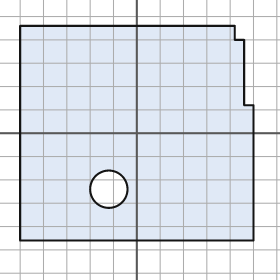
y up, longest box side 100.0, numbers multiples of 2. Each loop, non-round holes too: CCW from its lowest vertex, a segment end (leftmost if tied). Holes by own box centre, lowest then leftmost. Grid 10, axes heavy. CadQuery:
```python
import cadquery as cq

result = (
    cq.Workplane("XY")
    .moveTo(-50.0, -46.0)
    .lineTo(50.0, -46.0)
    .lineTo(50.0, 12.0)
    .lineTo(46.0, 12.0)
    .lineTo(46.0, 40.0)
    .lineTo(42.0, 40.0)
    .lineTo(42.0, 46.0)
    .lineTo(-50.0, 46.0)
    .close()
    .moveTo(-12.0, -24.0)
    .circle(8.0)
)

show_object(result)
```